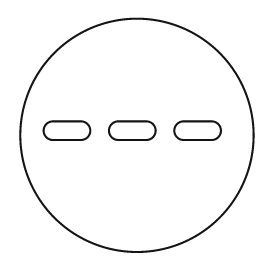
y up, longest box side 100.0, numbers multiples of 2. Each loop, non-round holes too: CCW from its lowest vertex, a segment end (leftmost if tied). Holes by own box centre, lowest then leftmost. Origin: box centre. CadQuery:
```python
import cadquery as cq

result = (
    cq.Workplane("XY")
    .moveTo(0.0, 0.0)
    .circle(50.0)
    .moveTo(-36.0, -2.0)
    .lineTo(-24.0, -2.0)
    .threePointArc((-20.0, 2.0), (-24.0, 6.0))
    .lineTo(-36.0, 6.0)
    .threePointArc((-40.0, 2.0), (-36.0, -2.0))
    .close()
    .moveTo(-8.0, -2.0)
    .lineTo(4.0, -2.0)
    .threePointArc((8.0, 2.0), (4.0, 6.0))
    .lineTo(-8.0, 6.0)
    .threePointArc((-12.0, 2.0), (-8.0, -2.0))
    .close()
    .moveTo(20.0, -2.0)
    .lineTo(32.0, -2.0)
    .threePointArc((36.0, 2.0), (32.0, 6.0))
    .lineTo(20.0, 6.0)
    .threePointArc((16.0, 2.0), (20.0, -2.0))
    .close()
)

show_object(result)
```